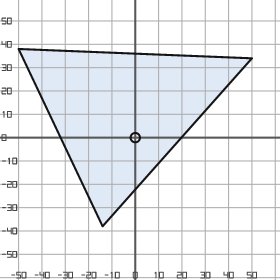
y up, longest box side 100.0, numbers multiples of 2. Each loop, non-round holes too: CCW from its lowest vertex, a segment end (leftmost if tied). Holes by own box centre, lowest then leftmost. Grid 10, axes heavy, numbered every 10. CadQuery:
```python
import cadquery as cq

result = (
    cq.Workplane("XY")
    .moveTo(-14.0, -38.0)
    .lineTo(50.0, 34.0)
    .lineTo(-50.0, 38.0)
    .close()
    .moveTo(0.0, 0.0)
    .circle(2.0)
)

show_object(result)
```